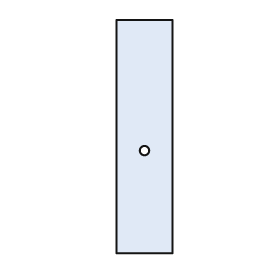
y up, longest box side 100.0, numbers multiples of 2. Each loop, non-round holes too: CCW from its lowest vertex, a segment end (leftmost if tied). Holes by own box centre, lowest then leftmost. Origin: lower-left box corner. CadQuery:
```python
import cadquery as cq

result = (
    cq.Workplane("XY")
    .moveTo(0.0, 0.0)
    .lineTo(24.0, 0.0)
    .lineTo(24.0, 100.0)
    .lineTo(0.0, 100.0)
    .close()
    .moveTo(12.0, 44.0)
    .circle(2.0)
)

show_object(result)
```